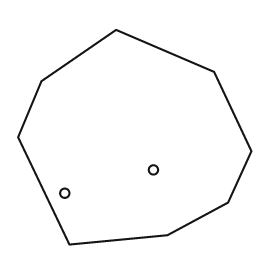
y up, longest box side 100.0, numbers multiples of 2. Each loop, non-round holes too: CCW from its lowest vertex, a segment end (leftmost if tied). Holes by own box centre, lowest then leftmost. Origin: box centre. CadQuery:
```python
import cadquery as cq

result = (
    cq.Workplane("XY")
    .moveTo(-28.0, -46.0)
    .lineTo(14.0, -42.0)
    .lineTo(40.0, -28.0)
    .lineTo(50.0, -6.0)
    .lineTo(34.0, 28.0)
    .lineTo(-8.0, 46.0)
    .lineTo(-40.0, 24.0)
    .lineTo(-50.0, 0.0)
    .close()
    .moveTo(-30.0, -24.0)
    .circle(2.0)
    .moveTo(8.0, -14.0)
    .circle(2.0)
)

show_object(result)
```